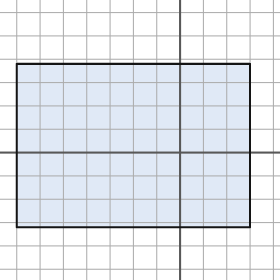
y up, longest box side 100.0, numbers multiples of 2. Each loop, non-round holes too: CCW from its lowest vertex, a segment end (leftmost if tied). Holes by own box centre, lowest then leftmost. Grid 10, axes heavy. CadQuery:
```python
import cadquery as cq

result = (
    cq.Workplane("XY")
    .moveTo(-70.0, -32.0)
    .lineTo(30.0, -32.0)
    .lineTo(30.0, 38.0)
    .lineTo(-70.0, 38.0)
    .close()
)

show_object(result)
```